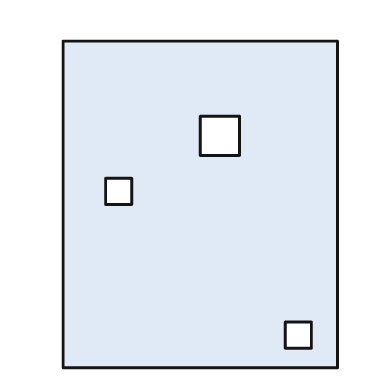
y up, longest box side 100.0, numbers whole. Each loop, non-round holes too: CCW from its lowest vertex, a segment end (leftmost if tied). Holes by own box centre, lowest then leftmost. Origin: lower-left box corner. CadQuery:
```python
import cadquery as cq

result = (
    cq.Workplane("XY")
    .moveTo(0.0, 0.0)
    .lineTo(84.0, 0.0)
    .lineTo(84.0, 100.0)
    .lineTo(0.0, 100.0)
    .close()
    .moveTo(68.0, 6.0)
    .lineTo(76.0, 6.0)
    .lineTo(76.0, 14.0)
    .lineTo(68.0, 14.0)
    .close()
    .moveTo(13.0, 50.0)
    .lineTo(21.0, 50.0)
    .lineTo(21.0, 58.0)
    .lineTo(13.0, 58.0)
    .close()
    .moveTo(42.0, 65.0)
    .lineTo(54.0, 65.0)
    .lineTo(54.0, 77.0)
    .lineTo(42.0, 77.0)
    .close()
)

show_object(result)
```